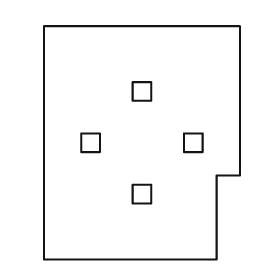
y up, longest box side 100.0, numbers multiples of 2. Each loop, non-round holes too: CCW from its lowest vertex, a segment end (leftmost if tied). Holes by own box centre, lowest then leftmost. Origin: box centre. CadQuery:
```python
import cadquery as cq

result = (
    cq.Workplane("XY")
    .moveTo(-42.0, -50.0)
    .lineTo(32.0, -50.0)
    .lineTo(32.0, -14.0)
    .lineTo(42.0, -14.0)
    .lineTo(42.0, 50.0)
    .lineTo(-42.0, 50.0)
    .close()
    .moveTo(-4.0, -26.0)
    .lineTo(4.0, -26.0)
    .lineTo(4.0, -18.0)
    .lineTo(-4.0, -18.0)
    .close()
    .moveTo(-26.0, -4.0)
    .lineTo(-18.0, -4.0)
    .lineTo(-18.0, 4.0)
    .lineTo(-26.0, 4.0)
    .close()
    .moveTo(18.0, -4.0)
    .lineTo(26.0, -4.0)
    .lineTo(26.0, 4.0)
    .lineTo(18.0, 4.0)
    .close()
    .moveTo(-4.0, 18.0)
    .lineTo(4.0, 18.0)
    .lineTo(4.0, 26.0)
    .lineTo(-4.0, 26.0)
    .close()
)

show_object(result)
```